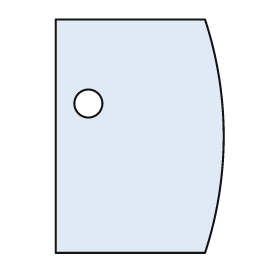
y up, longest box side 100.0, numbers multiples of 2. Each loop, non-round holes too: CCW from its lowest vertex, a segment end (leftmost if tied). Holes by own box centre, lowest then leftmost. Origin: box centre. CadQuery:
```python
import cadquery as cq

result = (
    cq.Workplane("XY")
    .moveTo(-36.0, -50.0)
    .lineTo(28.0, -50.0)
    .threePointArc((36.0, 0.0), (28.0, 50.0))
    .lineTo(-36.0, 50.0)
    .close()
    .moveTo(-22.0, 14.0)
    .circle(6.0)
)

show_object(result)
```